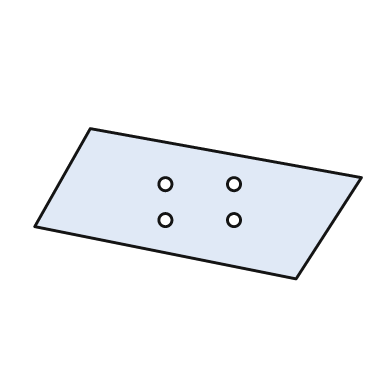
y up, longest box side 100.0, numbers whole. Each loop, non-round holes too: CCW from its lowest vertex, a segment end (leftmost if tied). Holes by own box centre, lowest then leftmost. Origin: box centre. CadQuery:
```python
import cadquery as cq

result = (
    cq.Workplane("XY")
    .moveTo(30.0, -23.0)
    .lineTo(50.0, 8.0)
    .lineTo(-33.0, 23.0)
    .lineTo(-50.0, -7.0)
    .close()
    .moveTo(-10.0, -5.0)
    .circle(2.0)
    .moveTo(11.0, -5.0)
    .circle(2.0)
    .moveTo(-10.0, 6.0)
    .circle(2.0)
    .moveTo(11.0, 6.0)
    .circle(2.0)
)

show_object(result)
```